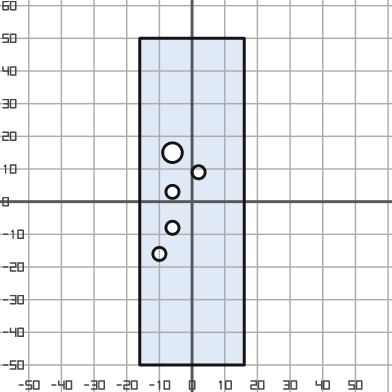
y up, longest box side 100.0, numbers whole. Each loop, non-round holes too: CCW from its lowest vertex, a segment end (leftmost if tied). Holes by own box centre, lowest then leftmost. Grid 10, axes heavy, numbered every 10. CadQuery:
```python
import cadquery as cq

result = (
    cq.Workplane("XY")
    .moveTo(-16.0, -50.0)
    .lineTo(16.0, -50.0)
    .lineTo(16.0, 50.0)
    .lineTo(-16.0, 50.0)
    .close()
    .moveTo(-10.0, -16.0)
    .circle(2.0)
    .moveTo(-6.0, -8.0)
    .circle(2.0)
    .moveTo(-6.0, 3.0)
    .circle(2.0)
    .moveTo(2.0, 9.0)
    .circle(2.0)
    .moveTo(-6.0, 15.0)
    .circle(3.0)
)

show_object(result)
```